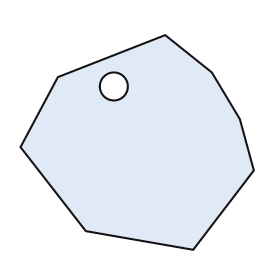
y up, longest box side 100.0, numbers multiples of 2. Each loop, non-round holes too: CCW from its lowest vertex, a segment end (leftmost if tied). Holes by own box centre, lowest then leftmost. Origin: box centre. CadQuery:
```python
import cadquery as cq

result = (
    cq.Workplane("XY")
    .moveTo(24.0, -46.0)
    .lineTo(50.0, -12.0)
    .lineTo(44.0, 10.0)
    .lineTo(32.0, 30.0)
    .lineTo(12.0, 46.0)
    .lineTo(-34.0, 28.0)
    .lineTo(-50.0, -2.0)
    .lineTo(-22.0, -38.0)
    .close()
    .moveTo(-10.0, 24.0)
    .circle(6.0)
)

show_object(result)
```